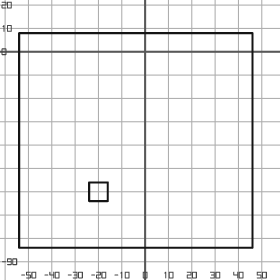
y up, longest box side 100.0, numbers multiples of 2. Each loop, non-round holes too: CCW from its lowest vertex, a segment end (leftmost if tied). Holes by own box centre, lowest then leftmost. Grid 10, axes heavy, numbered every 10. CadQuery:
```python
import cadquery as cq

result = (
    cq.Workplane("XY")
    .moveTo(-54.0, -84.0)
    .lineTo(46.0, -84.0)
    .lineTo(46.0, 8.0)
    .lineTo(-54.0, 8.0)
    .close()
    .moveTo(-24.0, -64.0)
    .lineTo(-16.0, -64.0)
    .lineTo(-16.0, -56.0)
    .lineTo(-24.0, -56.0)
    .close()
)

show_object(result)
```